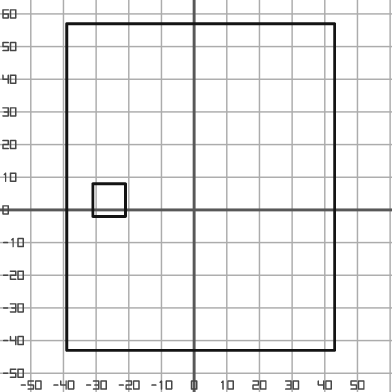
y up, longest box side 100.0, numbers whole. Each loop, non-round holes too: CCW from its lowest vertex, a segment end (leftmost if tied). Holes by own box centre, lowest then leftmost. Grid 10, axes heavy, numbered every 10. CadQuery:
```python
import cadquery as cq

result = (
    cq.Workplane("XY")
    .moveTo(-39.0, -43.0)
    .lineTo(43.0, -43.0)
    .lineTo(43.0, 57.0)
    .lineTo(-39.0, 57.0)
    .close()
    .moveTo(-31.0, -2.0)
    .lineTo(-21.0, -2.0)
    .lineTo(-21.0, 8.0)
    .lineTo(-31.0, 8.0)
    .close()
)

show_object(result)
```